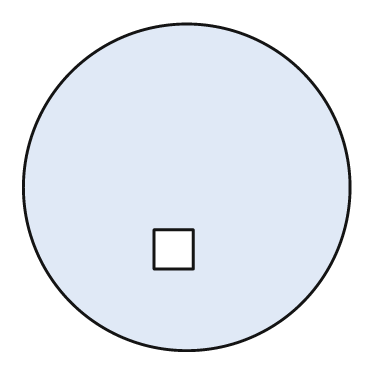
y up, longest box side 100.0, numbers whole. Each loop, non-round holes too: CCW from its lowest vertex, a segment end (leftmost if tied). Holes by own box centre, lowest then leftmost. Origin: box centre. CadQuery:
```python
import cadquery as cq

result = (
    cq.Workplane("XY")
    .moveTo(0.0, 0.0)
    .circle(50.0)
    .moveTo(-10.0, -25.0)
    .lineTo(2.0, -25.0)
    .lineTo(2.0, -13.0)
    .lineTo(-10.0, -13.0)
    .close()
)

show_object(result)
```